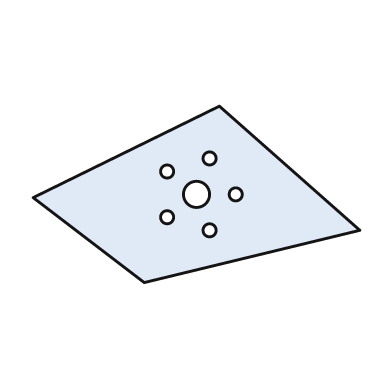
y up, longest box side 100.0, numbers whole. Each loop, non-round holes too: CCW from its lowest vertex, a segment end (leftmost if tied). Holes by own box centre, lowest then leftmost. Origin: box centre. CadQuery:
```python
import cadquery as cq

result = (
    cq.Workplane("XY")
    .moveTo(-16.0, -27.0)
    .lineTo(50.0, -11.0)
    .lineTo(7.0, 27.0)
    .lineTo(-50.0, -1.0)
    .close()
    .moveTo(4.0, -11.0)
    .circle(2.0)
    .moveTo(-9.0, -7.0)
    .circle(2.0)
    .moveTo(0.0, 0.0)
    .circle(4.0)
    .moveTo(12.0, 0.0)
    .circle(2.0)
    .moveTo(-9.0, 7.0)
    .circle(2.0)
    .moveTo(4.0, 11.0)
    .circle(2.0)
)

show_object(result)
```